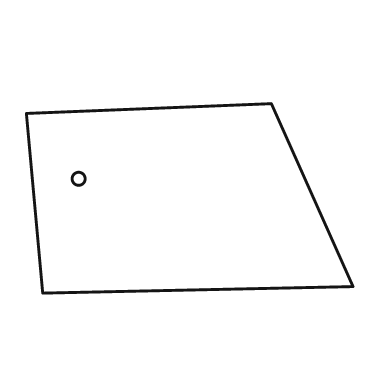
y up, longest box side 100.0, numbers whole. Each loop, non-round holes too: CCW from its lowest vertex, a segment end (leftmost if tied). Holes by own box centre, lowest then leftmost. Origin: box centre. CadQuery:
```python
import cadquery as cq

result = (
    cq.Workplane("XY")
    .moveTo(-45.0, -29.0)
    .lineTo(50.0, -27.0)
    .lineTo(25.0, 29.0)
    .lineTo(-50.0, 26.0)
    .close()
    .moveTo(-34.0, 6.0)
    .circle(2.0)
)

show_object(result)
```